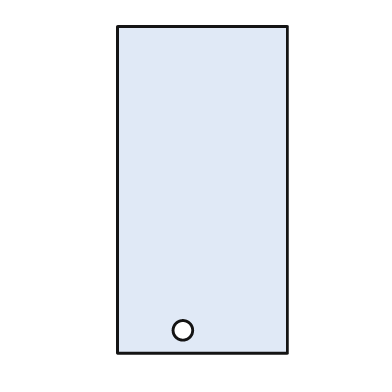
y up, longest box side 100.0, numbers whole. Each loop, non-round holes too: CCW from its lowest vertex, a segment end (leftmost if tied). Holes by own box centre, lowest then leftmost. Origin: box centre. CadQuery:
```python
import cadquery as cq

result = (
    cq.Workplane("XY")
    .moveTo(-26.0, -50.0)
    .lineTo(26.0, -50.0)
    .lineTo(26.0, 50.0)
    .lineTo(-26.0, 50.0)
    .close()
    .moveTo(-6.0, -43.0)
    .circle(3.0)
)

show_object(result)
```